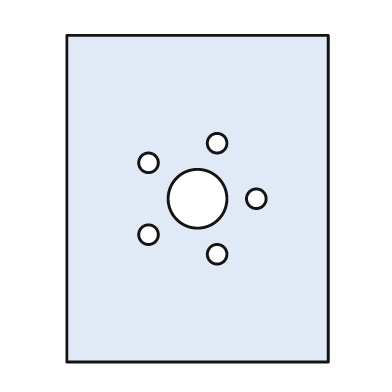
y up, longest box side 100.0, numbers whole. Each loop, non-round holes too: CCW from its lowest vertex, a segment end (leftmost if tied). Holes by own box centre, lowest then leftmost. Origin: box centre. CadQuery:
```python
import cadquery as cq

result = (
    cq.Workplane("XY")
    .moveTo(-40.0, -50.0)
    .lineTo(40.0, -50.0)
    .lineTo(40.0, 50.0)
    .lineTo(-40.0, 50.0)
    .close()
    .moveTo(6.0, -17.0)
    .circle(3.0)
    .moveTo(-15.0, -11.0)
    .circle(3.0)
    .moveTo(0.0, 0.0)
    .circle(9.0)
    .moveTo(18.0, 0.0)
    .circle(3.0)
    .moveTo(-15.0, 11.0)
    .circle(3.0)
    .moveTo(6.0, 17.0)
    .circle(3.0)
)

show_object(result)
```